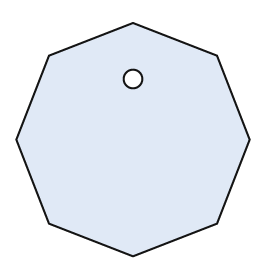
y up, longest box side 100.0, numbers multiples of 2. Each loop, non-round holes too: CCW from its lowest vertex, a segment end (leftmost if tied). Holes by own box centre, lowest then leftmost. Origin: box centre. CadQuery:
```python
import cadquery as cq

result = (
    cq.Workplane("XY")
    .moveTo(0.0, -50.0)
    .lineTo(36.0, -36.0)
    .lineTo(50.0, 0.0)
    .lineTo(36.0, 36.0)
    .lineTo(0.0, 50.0)
    .lineTo(-36.0, 36.0)
    .lineTo(-50.0, 0.0)
    .lineTo(-36.0, -36.0)
    .close()
    .moveTo(0.0, 26.0)
    .circle(4.0)
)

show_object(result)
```